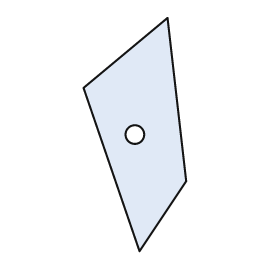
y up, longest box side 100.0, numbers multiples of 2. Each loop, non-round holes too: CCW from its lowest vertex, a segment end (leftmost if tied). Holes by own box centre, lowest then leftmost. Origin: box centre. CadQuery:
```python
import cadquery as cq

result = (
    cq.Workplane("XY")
    .moveTo(2.0, -50.0)
    .lineTo(22.0, -20.0)
    .lineTo(14.0, 50.0)
    .lineTo(-22.0, 20.0)
    .close()
    .moveTo(0.0, 0.0)
    .circle(4.0)
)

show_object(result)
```